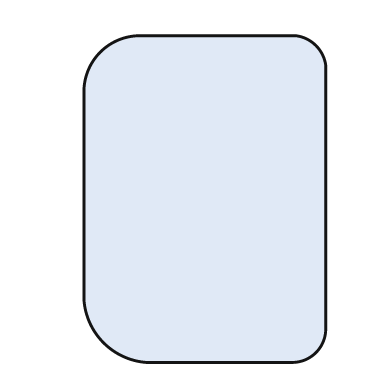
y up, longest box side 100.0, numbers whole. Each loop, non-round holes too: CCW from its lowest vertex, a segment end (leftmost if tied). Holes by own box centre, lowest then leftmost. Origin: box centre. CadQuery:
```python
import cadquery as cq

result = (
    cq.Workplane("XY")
    .moveTo(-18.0, -50.0)
    .lineTo(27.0, -50.0)
    .threePointArc((34.0, -47.0), (37.0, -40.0))
    .lineTo(37.0, 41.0)
    .threePointArc((34.0, 47.0), (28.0, 50.0))
    .lineTo(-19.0, 50.0)
    .threePointArc((-32.0, 45.0), (-37.0, 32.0))
    .lineTo(-37.0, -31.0)
    .threePointArc((-31.0, -44.0), (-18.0, -50.0))
    .close()
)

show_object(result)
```